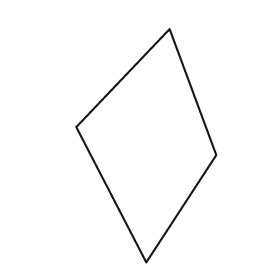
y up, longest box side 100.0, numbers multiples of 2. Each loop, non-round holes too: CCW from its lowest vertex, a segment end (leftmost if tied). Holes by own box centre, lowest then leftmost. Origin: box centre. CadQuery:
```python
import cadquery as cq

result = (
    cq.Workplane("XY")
    .moveTo(0.0, -50.0)
    .lineTo(30.0, -4.0)
    .lineTo(10.0, 50.0)
    .lineTo(-30.0, 8.0)
    .close()
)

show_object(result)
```